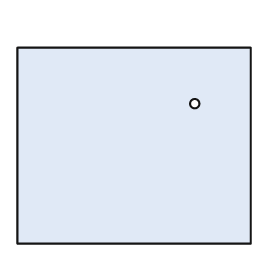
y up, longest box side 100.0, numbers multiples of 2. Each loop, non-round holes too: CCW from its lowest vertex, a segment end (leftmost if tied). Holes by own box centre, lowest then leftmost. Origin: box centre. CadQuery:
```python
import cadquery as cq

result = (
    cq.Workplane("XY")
    .moveTo(-50.0, -42.0)
    .lineTo(50.0, -42.0)
    .lineTo(50.0, 42.0)
    .lineTo(-50.0, 42.0)
    .close()
    .moveTo(26.0, 18.0)
    .circle(2.0)
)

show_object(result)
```